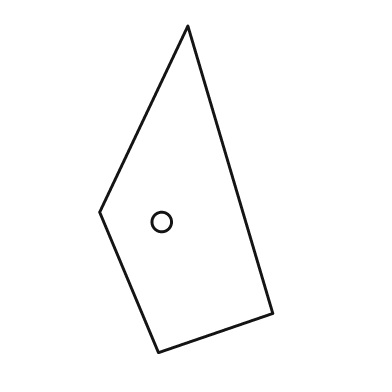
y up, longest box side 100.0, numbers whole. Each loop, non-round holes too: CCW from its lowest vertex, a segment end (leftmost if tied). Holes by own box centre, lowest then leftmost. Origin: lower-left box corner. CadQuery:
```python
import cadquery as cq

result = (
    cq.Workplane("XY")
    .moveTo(18.0, 0.0)
    .lineTo(53.0, 12.0)
    .lineTo(27.0, 100.0)
    .lineTo(0.0, 43.0)
    .close()
    .moveTo(19.0, 40.0)
    .circle(3.0)
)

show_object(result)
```